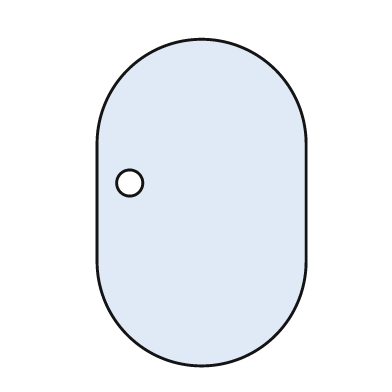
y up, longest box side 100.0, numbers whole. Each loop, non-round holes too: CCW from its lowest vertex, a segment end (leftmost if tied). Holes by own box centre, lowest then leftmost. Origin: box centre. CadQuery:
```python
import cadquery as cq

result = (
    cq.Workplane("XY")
    .moveTo(-32.0, -18.0)
    .threePointArc((0.0, -50.0), (32.0, -18.0))
    .lineTo(32.0, 18.0)
    .threePointArc((0.0, 50.0), (-32.0, 18.0))
    .close()
    .moveTo(-22.0, 6.0)
    .circle(4.0)
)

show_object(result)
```